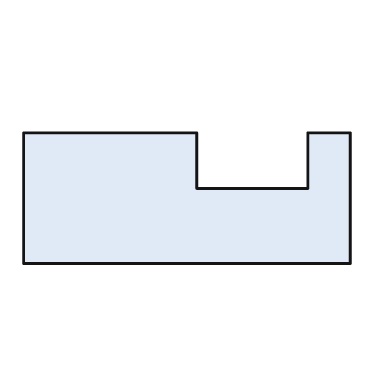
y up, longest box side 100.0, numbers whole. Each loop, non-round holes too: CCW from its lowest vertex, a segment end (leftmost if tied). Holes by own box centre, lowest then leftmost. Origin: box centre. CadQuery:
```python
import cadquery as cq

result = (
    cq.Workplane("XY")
    .moveTo(-50.0, -20.0)
    .lineTo(50.0, -20.0)
    .lineTo(50.0, 20.0)
    .lineTo(37.0, 20.0)
    .lineTo(37.0, 3.0)
    .lineTo(3.0, 3.0)
    .lineTo(3.0, 20.0)
    .lineTo(-50.0, 20.0)
    .close()
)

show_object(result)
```